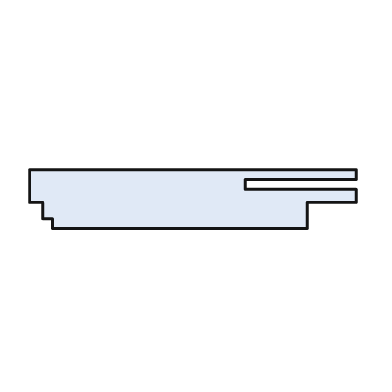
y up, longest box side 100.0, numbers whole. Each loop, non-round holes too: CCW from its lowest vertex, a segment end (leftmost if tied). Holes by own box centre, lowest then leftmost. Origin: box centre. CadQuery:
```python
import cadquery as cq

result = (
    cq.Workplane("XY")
    .moveTo(-43.0, -9.0)
    .lineTo(35.0, -9.0)
    .lineTo(35.0, -1.0)
    .lineTo(50.0, -1.0)
    .lineTo(50.0, 3.0)
    .lineTo(16.0, 3.0)
    .lineTo(16.0, 6.0)
    .lineTo(50.0, 6.0)
    .lineTo(50.0, 9.0)
    .lineTo(-50.0, 9.0)
    .lineTo(-50.0, -1.0)
    .lineTo(-46.0, -1.0)
    .lineTo(-46.0, -6.0)
    .lineTo(-43.0, -6.0)
    .close()
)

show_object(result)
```